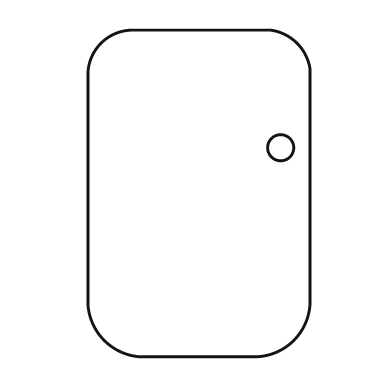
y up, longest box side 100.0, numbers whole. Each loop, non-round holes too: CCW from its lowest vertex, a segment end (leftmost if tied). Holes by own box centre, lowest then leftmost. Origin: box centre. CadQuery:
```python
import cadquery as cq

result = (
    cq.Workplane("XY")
    .moveTo(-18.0, -50.0)
    .lineTo(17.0, -50.0)
    .threePointArc((29.0, -45.0), (34.0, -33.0))
    .lineTo(34.0, 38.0)
    .threePointArc((30.0, 46.0), (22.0, 50.0))
    .lineTo(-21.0, 50.0)
    .threePointArc((-30.0, 46.0), (-34.0, 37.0))
    .lineTo(-34.0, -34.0)
    .threePointArc((-29.0, -45.0), (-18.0, -50.0))
    .close()
    .moveTo(25.0, 14.0)
    .circle(4.0)
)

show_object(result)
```